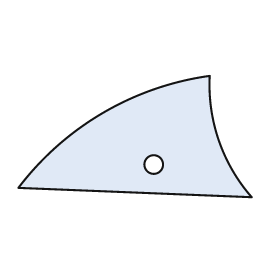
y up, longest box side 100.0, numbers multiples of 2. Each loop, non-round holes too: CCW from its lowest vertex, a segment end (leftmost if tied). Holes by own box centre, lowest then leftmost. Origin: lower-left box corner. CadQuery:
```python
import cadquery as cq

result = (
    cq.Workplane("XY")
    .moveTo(100.0, 0.0)
    .threePointArc((86.0, 24.0), (82.0, 52.0))
    .threePointArc((36.0, 36.0), (0.0, 4.0))
    .close()
    .moveTo(58.0, 14.0)
    .circle(4.0)
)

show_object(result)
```